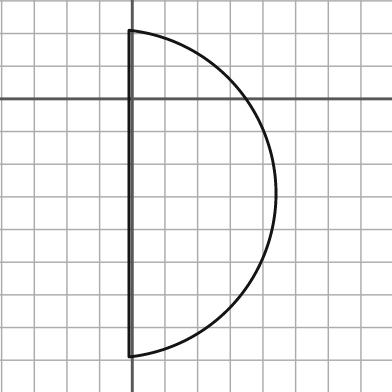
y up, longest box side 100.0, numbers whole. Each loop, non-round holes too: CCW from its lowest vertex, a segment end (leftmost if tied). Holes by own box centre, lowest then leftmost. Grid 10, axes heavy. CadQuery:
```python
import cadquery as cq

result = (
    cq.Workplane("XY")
    .moveTo(-1.0, -79.0)
    .threePointArc((44.0, -29.0), (-1.0, 21.0))
    .close()
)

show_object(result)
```